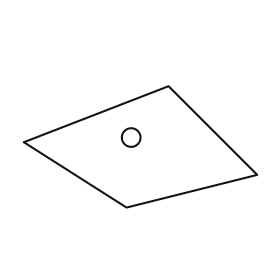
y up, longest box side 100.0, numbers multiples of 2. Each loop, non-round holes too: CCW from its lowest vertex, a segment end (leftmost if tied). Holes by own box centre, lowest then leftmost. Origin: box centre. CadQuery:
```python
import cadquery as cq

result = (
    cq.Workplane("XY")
    .moveTo(-6.0, -26.0)
    .lineTo(50.0, -12.0)
    .lineTo(12.0, 26.0)
    .lineTo(-50.0, 2.0)
    .close()
    .moveTo(-4.0, 4.0)
    .circle(4.0)
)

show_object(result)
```